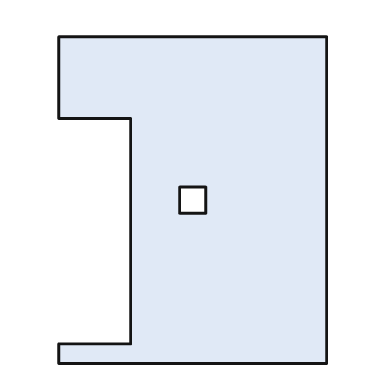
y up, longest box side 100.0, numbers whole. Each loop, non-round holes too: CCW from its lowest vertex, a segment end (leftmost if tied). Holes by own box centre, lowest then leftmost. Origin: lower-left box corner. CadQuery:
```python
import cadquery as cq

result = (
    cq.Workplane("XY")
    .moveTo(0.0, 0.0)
    .lineTo(82.0, 0.0)
    .lineTo(82.0, 100.0)
    .lineTo(0.0, 100.0)
    .lineTo(0.0, 75.0)
    .lineTo(22.0, 75.0)
    .lineTo(22.0, 6.0)
    .lineTo(0.0, 6.0)
    .close()
    .moveTo(37.0, 46.0)
    .lineTo(45.0, 46.0)
    .lineTo(45.0, 54.0)
    .lineTo(37.0, 54.0)
    .close()
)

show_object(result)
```